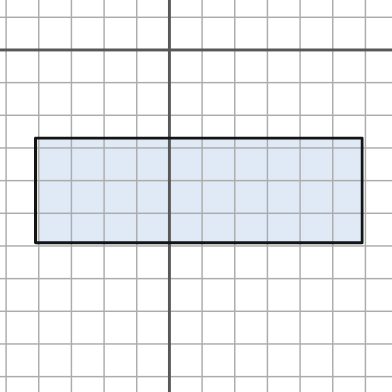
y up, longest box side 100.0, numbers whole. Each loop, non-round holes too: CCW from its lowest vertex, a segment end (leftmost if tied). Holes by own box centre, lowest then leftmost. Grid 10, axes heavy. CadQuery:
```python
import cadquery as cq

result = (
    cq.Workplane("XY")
    .moveTo(-41.0, -59.0)
    .lineTo(59.0, -59.0)
    .lineTo(59.0, -27.0)
    .lineTo(-41.0, -27.0)
    .close()
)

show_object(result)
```